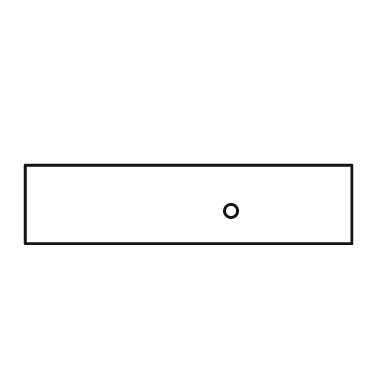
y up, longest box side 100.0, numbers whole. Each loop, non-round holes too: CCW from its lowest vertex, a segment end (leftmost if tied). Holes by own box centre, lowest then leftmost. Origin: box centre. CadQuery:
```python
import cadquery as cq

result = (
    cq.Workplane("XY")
    .moveTo(-50.0, -12.0)
    .lineTo(50.0, -12.0)
    .lineTo(50.0, 12.0)
    .lineTo(-50.0, 12.0)
    .close()
    .moveTo(13.0, -2.0)
    .circle(2.0)
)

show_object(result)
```